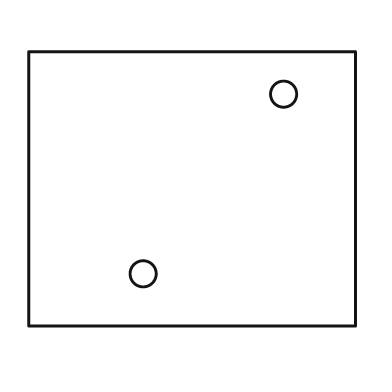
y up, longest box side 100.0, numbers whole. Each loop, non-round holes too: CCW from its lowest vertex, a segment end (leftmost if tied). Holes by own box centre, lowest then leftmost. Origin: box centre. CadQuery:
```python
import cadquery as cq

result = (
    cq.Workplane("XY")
    .moveTo(-50.0, -42.0)
    .lineTo(50.0, -42.0)
    .lineTo(50.0, 42.0)
    .lineTo(-50.0, 42.0)
    .close()
    .moveTo(-15.0, -26.0)
    .circle(4.0)
    .moveTo(28.0, 29.0)
    .circle(4.0)
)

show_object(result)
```